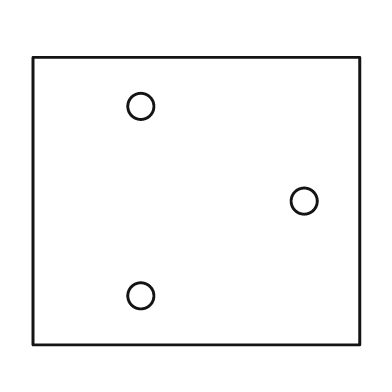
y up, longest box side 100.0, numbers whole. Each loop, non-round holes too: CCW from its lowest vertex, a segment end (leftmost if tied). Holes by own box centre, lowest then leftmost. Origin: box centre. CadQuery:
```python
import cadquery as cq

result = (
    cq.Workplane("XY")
    .moveTo(-50.0, -44.0)
    .lineTo(50.0, -44.0)
    .lineTo(50.0, 44.0)
    .lineTo(-50.0, 44.0)
    .close()
    .moveTo(-17.0, -29.0)
    .circle(4.0)
    .moveTo(33.0, 0.0)
    .circle(4.0)
    .moveTo(-17.0, 29.0)
    .circle(4.0)
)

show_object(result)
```